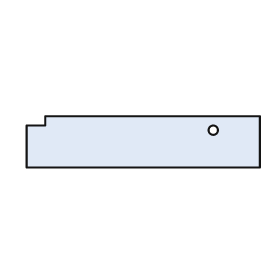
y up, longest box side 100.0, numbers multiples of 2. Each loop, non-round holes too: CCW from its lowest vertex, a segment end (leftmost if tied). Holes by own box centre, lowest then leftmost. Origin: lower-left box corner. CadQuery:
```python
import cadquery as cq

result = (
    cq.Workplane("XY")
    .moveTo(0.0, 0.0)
    .lineTo(100.0, 0.0)
    .lineTo(100.0, 22.0)
    .lineTo(8.0, 22.0)
    .lineTo(8.0, 18.0)
    .lineTo(0.0, 18.0)
    .close()
    .moveTo(80.0, 16.0)
    .circle(2.0)
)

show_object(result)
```